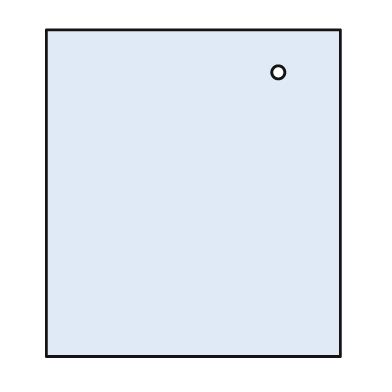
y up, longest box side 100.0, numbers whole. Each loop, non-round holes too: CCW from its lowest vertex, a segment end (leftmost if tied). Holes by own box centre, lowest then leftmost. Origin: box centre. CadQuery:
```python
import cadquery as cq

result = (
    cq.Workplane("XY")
    .moveTo(-45.0, -50.0)
    .lineTo(45.0, -50.0)
    .lineTo(45.0, 50.0)
    .lineTo(-45.0, 50.0)
    .close()
    .moveTo(26.0, 37.0)
    .circle(2.0)
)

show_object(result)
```